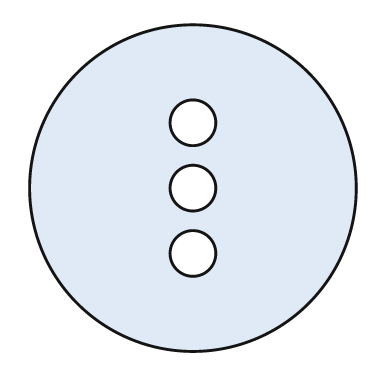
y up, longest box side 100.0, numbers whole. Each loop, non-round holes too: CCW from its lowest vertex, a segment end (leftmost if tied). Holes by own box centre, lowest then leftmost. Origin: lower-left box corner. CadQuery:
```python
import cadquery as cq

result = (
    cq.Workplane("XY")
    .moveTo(50.0, 50.0)
    .circle(50.0)
    .moveTo(50.0, 30.0)
    .circle(7.0)
    .moveTo(50.0, 50.0)
    .circle(7.0)
    .moveTo(50.0, 70.0)
    .circle(7.0)
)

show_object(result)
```